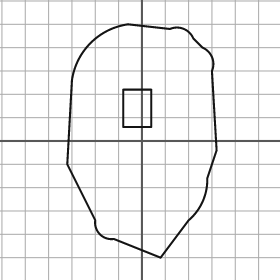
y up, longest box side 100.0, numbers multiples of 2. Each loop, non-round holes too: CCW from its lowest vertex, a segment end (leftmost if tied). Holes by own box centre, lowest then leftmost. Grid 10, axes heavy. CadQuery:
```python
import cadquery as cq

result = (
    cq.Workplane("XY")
    .moveTo(8.0, -50.0)
    .lineTo(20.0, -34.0)
    .threePointArc((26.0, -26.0), (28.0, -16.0))
    .lineTo(32.0, -4.0)
    .lineTo(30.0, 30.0)
    .threePointArc((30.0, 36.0), (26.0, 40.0))
    .lineTo(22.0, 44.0)
    .threePointArc((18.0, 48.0), (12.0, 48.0))
    .lineTo(-6.0, 50.0)
    .threePointArc((-22.0, 42.0), (-30.0, 26.0))
    .lineTo(-32.0, -10.0)
    .lineTo(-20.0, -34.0)
    .threePointArc((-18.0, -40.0), (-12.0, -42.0))
    .close()
    .moveTo(-8.0, 6.0)
    .lineTo(4.0, 6.0)
    .lineTo(4.0, 22.0)
    .lineTo(-8.0, 22.0)
    .close()
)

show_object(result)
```